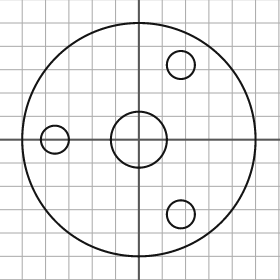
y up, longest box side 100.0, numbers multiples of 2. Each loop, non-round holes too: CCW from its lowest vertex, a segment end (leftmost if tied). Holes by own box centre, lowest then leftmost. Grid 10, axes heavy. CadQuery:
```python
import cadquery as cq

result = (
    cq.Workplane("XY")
    .moveTo(0.0, 0.0)
    .circle(50.0)
    .moveTo(18.0, -32.0)
    .circle(6.0)
    .moveTo(-36.0, 0.0)
    .circle(6.0)
    .moveTo(0.0, 0.0)
    .circle(12.0)
    .moveTo(18.0, 32.0)
    .circle(6.0)
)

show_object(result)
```